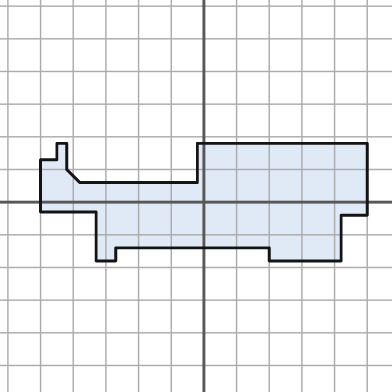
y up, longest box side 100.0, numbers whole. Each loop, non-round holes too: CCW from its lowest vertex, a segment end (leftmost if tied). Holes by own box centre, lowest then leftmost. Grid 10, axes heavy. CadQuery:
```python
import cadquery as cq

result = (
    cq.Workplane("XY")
    .moveTo(-33.0, -18.0)
    .lineTo(-27.0, -18.0)
    .lineTo(-27.0, -14.0)
    .lineTo(20.0, -14.0)
    .lineTo(20.0, -18.0)
    .lineTo(42.0, -18.0)
    .lineTo(42.0, -4.0)
    .lineTo(50.0, -4.0)
    .lineTo(50.0, 18.0)
    .lineTo(-2.0, 18.0)
    .lineTo(-2.0, 6.0)
    .lineTo(-38.0, 6.0)
    .lineTo(-42.0, 10.0)
    .lineTo(-42.0, 18.0)
    .lineTo(-45.0, 18.0)
    .lineTo(-45.0, 13.0)
    .lineTo(-50.0, 13.0)
    .lineTo(-50.0, -3.0)
    .lineTo(-33.0, -3.0)
    .close()
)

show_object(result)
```